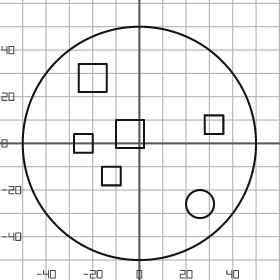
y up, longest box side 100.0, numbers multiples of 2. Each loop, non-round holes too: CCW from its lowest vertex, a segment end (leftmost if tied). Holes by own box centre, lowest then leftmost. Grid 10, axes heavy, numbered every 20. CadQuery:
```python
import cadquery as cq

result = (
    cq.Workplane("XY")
    .moveTo(0.0, 0.0)
    .circle(50.0)
    .moveTo(26.0, -26.0)
    .circle(6.0)
    .moveTo(-16.0, -18.0)
    .lineTo(-8.0, -18.0)
    .lineTo(-8.0, -10.0)
    .lineTo(-16.0, -10.0)
    .close()
    .moveTo(-28.0, -4.0)
    .lineTo(-20.0, -4.0)
    .lineTo(-20.0, 4.0)
    .lineTo(-28.0, 4.0)
    .close()
    .moveTo(-10.0, -2.0)
    .lineTo(2.0, -2.0)
    .lineTo(2.0, 10.0)
    .lineTo(-10.0, 10.0)
    .close()
    .moveTo(28.0, 4.0)
    .lineTo(36.0, 4.0)
    .lineTo(36.0, 12.0)
    .lineTo(28.0, 12.0)
    .close()
    .moveTo(-26.0, 22.0)
    .lineTo(-14.0, 22.0)
    .lineTo(-14.0, 34.0)
    .lineTo(-26.0, 34.0)
    .close()
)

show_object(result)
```